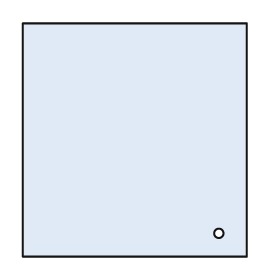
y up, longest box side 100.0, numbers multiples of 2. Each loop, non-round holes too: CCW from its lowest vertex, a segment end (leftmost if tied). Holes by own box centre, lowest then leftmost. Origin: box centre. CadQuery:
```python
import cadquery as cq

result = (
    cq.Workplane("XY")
    .moveTo(-48.0, -50.0)
    .lineTo(48.0, -50.0)
    .lineTo(48.0, 50.0)
    .lineTo(-48.0, 50.0)
    .close()
    .moveTo(36.0, -40.0)
    .circle(2.0)
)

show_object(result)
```